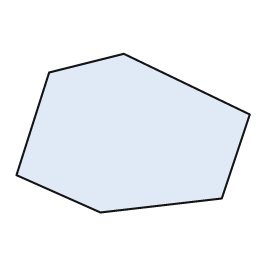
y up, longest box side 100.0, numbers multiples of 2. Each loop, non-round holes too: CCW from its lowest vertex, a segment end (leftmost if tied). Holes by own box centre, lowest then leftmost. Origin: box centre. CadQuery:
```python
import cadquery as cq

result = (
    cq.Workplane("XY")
    .moveTo(-14.0, -34.0)
    .lineTo(38.0, -28.0)
    .lineTo(50.0, 8.0)
    .lineTo(-4.0, 34.0)
    .lineTo(-36.0, 26.0)
    .lineTo(-50.0, -18.0)
    .close()
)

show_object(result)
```